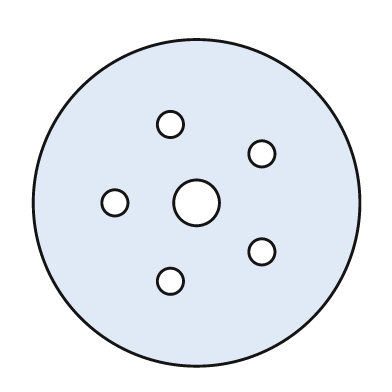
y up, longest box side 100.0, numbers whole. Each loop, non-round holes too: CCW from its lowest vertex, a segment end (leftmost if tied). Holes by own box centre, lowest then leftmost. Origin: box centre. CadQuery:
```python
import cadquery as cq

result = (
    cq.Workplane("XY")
    .moveTo(0.0, 0.0)
    .circle(50.0)
    .moveTo(-8.0, -24.0)
    .circle(4.0)
    .moveTo(20.0, -15.0)
    .circle(4.0)
    .moveTo(-25.0, 0.0)
    .circle(4.0)
    .moveTo(0.0, 0.0)
    .circle(7.0)
    .moveTo(20.0, 15.0)
    .circle(4.0)
    .moveTo(-8.0, 24.0)
    .circle(4.0)
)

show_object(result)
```